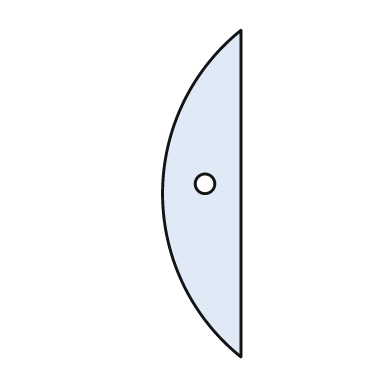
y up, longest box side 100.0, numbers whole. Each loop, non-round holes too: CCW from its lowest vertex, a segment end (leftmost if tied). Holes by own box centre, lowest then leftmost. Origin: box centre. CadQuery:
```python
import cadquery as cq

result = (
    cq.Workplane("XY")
    .moveTo(12.0, -50.0)
    .lineTo(12.0, 50.0)
    .threePointArc((-12.0, 0.0), (12.0, -50.0))
    .close()
    .moveTo(1.0, 3.0)
    .circle(3.0)
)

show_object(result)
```